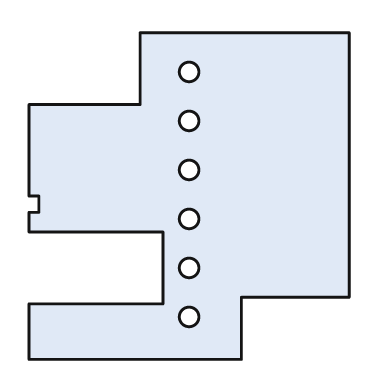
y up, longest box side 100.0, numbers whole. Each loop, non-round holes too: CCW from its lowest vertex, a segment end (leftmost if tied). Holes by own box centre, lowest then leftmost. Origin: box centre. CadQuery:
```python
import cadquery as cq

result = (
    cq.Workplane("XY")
    .moveTo(-49.0, -50.0)
    .lineTo(16.0, -50.0)
    .lineTo(16.0, -31.0)
    .lineTo(49.0, -31.0)
    .lineTo(49.0, 50.0)
    .lineTo(-15.0, 50.0)
    .lineTo(-15.0, 28.0)
    .lineTo(-49.0, 28.0)
    .lineTo(-49.0, 0.0)
    .lineTo(-46.0, 0.0)
    .lineTo(-46.0, -5.0)
    .lineTo(-49.0, -5.0)
    .lineTo(-49.0, -11.0)
    .lineTo(-8.0, -11.0)
    .lineTo(-8.0, -33.0)
    .lineTo(-49.0, -33.0)
    .close()
    .moveTo(0.0, -37.0)
    .circle(3.0)
    .moveTo(0.0, -22.0)
    .circle(3.0)
    .moveTo(0.0, -7.0)
    .circle(3.0)
    .moveTo(0.0, 8.0)
    .circle(3.0)
    .moveTo(0.0, 23.0)
    .circle(3.0)
    .moveTo(0.0, 38.0)
    .circle(3.0)
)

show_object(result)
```